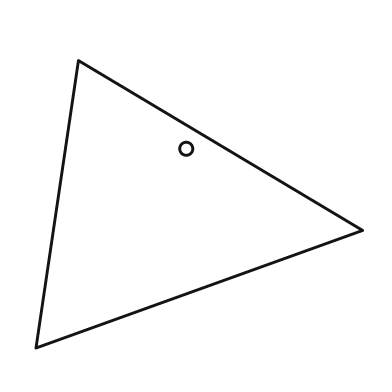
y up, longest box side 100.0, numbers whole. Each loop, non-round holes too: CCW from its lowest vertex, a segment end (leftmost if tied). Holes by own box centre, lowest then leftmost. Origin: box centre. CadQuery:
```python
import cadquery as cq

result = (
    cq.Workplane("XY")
    .moveTo(-50.0, -44.0)
    .lineTo(50.0, -8.0)
    .lineTo(-37.0, 44.0)
    .close()
    .moveTo(-4.0, 17.0)
    .circle(2.0)
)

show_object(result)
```